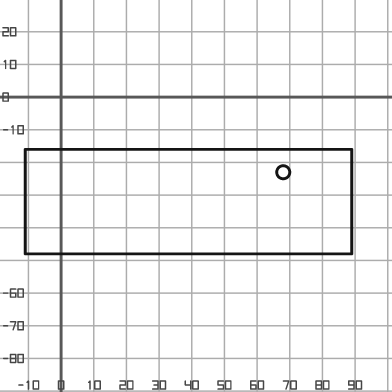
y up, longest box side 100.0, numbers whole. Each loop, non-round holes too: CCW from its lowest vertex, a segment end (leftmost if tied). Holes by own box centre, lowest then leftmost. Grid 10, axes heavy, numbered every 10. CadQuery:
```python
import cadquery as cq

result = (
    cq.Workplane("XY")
    .moveTo(-11.0, -48.0)
    .lineTo(89.0, -48.0)
    .lineTo(89.0, -16.0)
    .lineTo(-11.0, -16.0)
    .close()
    .moveTo(68.0, -23.0)
    .circle(2.0)
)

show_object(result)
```